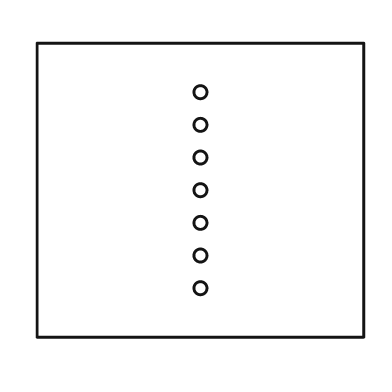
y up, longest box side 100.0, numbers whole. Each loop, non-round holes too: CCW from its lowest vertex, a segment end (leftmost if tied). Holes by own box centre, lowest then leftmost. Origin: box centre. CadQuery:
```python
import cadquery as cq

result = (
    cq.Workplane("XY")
    .moveTo(-50.0, -45.0)
    .lineTo(50.0, -45.0)
    .lineTo(50.0, 45.0)
    .lineTo(-50.0, 45.0)
    .close()
    .moveTo(0.0, -30.0)
    .circle(2.0)
    .moveTo(0.0, -20.0)
    .circle(2.0)
    .moveTo(0.0, -10.0)
    .circle(2.0)
    .moveTo(0.0, 0.0)
    .circle(2.0)
    .moveTo(0.0, 10.0)
    .circle(2.0)
    .moveTo(0.0, 20.0)
    .circle(2.0)
    .moveTo(0.0, 30.0)
    .circle(2.0)
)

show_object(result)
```